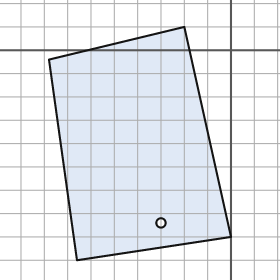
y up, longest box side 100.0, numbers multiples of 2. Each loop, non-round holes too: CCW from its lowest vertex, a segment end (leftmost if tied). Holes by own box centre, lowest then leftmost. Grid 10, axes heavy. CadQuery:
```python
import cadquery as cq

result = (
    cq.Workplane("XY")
    .moveTo(-66.0, -90.0)
    .lineTo(0.0, -80.0)
    .lineTo(-20.0, 10.0)
    .lineTo(-78.0, -4.0)
    .close()
    .moveTo(-30.0, -74.0)
    .circle(2.0)
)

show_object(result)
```